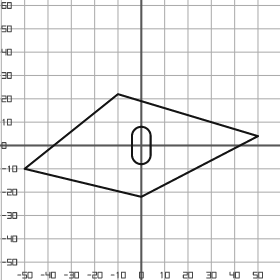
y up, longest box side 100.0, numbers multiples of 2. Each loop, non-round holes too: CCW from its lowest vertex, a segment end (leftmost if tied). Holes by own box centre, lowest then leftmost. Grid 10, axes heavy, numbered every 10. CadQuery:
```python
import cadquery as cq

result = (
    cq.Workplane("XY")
    .moveTo(0.0, -22.0)
    .lineTo(50.0, 4.0)
    .lineTo(-10.0, 22.0)
    .lineTo(-50.0, -10.0)
    .close()
    .moveTo(-4.0, -4.0)
    .threePointArc((0.0, -8.0), (4.0, -4.0))
    .lineTo(4.0, 4.0)
    .threePointArc((0.0, 8.0), (-4.0, 4.0))
    .close()
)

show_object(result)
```